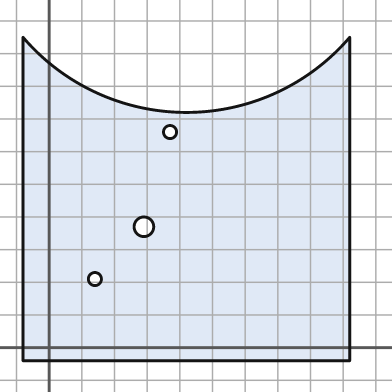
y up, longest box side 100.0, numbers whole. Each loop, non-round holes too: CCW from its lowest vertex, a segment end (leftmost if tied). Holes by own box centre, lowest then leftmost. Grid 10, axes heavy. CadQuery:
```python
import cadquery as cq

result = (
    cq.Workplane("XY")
    .moveTo(-8.0, -4.0)
    .lineTo(92.0, -4.0)
    .lineTo(92.0, 95.0)
    .threePointArc((42.0, 72.0), (-8.0, 95.0))
    .close()
    .moveTo(14.0, 21.0)
    .circle(2.0)
    .moveTo(29.0, 37.0)
    .circle(3.0)
    .moveTo(37.0, 66.0)
    .circle(2.0)
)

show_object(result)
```